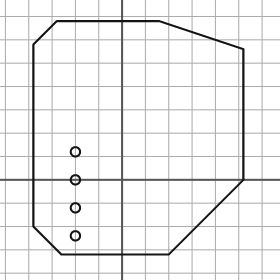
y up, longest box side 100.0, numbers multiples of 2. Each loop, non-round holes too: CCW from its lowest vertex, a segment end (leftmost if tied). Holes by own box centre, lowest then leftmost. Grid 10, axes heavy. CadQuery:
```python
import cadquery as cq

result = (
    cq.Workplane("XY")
    .moveTo(-26.0, -32.0)
    .lineTo(20.0, -32.0)
    .lineTo(52.0, 0.0)
    .lineTo(52.0, 56.0)
    .lineTo(16.0, 68.0)
    .lineTo(-28.0, 68.0)
    .lineTo(-38.0, 58.0)
    .lineTo(-38.0, -20.0)
    .close()
    .moveTo(-20.0, -24.0)
    .circle(2.0)
    .moveTo(-20.0, -12.0)
    .circle(2.0)
    .moveTo(-20.0, 0.0)
    .circle(2.0)
    .moveTo(-20.0, 12.0)
    .circle(2.0)
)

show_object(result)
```